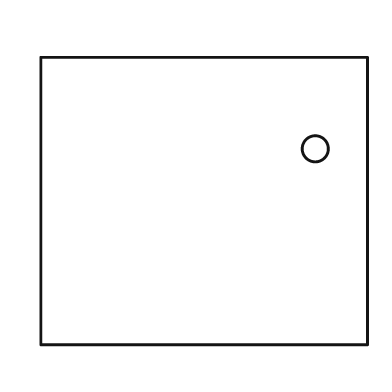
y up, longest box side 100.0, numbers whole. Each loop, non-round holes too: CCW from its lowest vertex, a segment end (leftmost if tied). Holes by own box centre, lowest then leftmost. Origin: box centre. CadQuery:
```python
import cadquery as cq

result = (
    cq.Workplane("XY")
    .moveTo(-50.0, -44.0)
    .lineTo(50.0, -44.0)
    .lineTo(50.0, 44.0)
    .lineTo(-50.0, 44.0)
    .close()
    .moveTo(34.0, 16.0)
    .circle(4.0)
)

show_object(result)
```